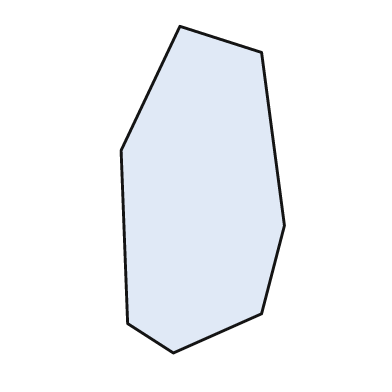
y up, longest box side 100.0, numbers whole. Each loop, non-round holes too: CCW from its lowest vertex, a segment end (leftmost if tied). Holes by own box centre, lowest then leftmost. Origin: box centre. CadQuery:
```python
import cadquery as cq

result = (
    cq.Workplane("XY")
    .moveTo(-9.0, -50.0)
    .lineTo(18.0, -38.0)
    .lineTo(25.0, -11.0)
    .lineTo(18.0, 42.0)
    .lineTo(-7.0, 50.0)
    .lineTo(-25.0, 12.0)
    .lineTo(-23.0, -41.0)
    .close()
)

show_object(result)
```